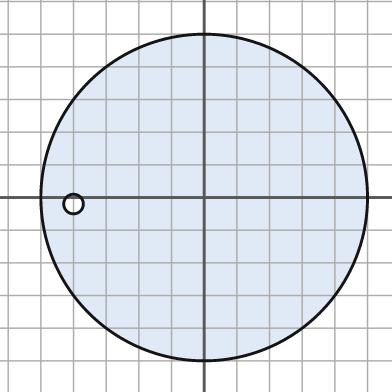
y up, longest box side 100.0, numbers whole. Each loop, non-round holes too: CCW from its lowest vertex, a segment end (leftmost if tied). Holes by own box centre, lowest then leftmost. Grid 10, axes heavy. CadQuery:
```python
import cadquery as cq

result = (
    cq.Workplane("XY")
    .moveTo(0.0, 0.0)
    .circle(50.0)
    .moveTo(-40.0, -2.0)
    .circle(3.0)
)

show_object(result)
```